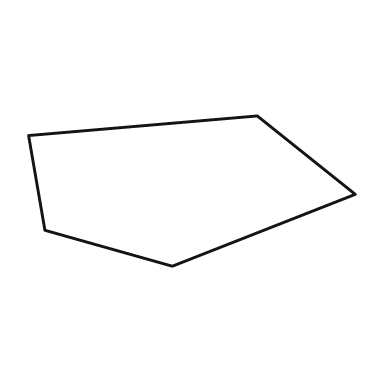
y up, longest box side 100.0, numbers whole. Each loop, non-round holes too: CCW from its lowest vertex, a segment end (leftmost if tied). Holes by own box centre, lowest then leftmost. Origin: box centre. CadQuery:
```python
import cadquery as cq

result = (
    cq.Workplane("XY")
    .moveTo(-6.0, -23.0)
    .lineTo(50.0, -1.0)
    .lineTo(20.0, 23.0)
    .lineTo(-50.0, 17.0)
    .lineTo(-45.0, -12.0)
    .close()
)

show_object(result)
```